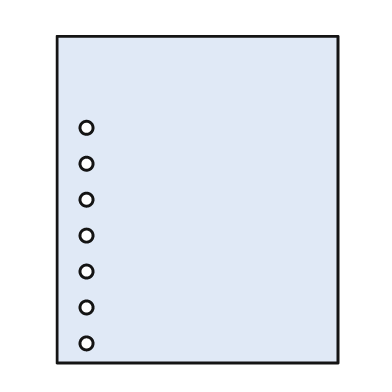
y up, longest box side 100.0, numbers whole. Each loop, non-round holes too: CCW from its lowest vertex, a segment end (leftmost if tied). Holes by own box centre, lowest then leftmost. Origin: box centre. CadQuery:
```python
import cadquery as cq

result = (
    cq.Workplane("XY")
    .moveTo(-43.0, -50.0)
    .lineTo(43.0, -50.0)
    .lineTo(43.0, 50.0)
    .lineTo(-43.0, 50.0)
    .close()
    .moveTo(-34.0, -44.0)
    .circle(2.0)
    .moveTo(-34.0, -33.0)
    .circle(2.0)
    .moveTo(-34.0, -22.0)
    .circle(2.0)
    .moveTo(-34.0, -11.0)
    .circle(2.0)
    .moveTo(-34.0, 0.0)
    .circle(2.0)
    .moveTo(-34.0, 11.0)
    .circle(2.0)
    .moveTo(-34.0, 22.0)
    .circle(2.0)
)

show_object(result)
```